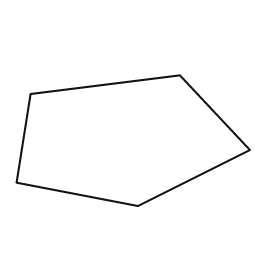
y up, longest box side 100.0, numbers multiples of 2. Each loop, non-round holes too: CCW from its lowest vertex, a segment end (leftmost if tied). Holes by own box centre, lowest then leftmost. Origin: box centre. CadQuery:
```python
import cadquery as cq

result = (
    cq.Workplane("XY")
    .moveTo(2.0, -28.0)
    .lineTo(50.0, -4.0)
    .lineTo(20.0, 28.0)
    .lineTo(-44.0, 20.0)
    .lineTo(-50.0, -18.0)
    .close()
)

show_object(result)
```